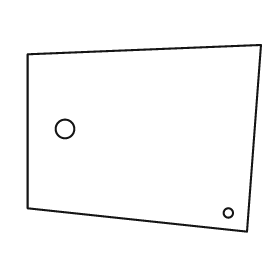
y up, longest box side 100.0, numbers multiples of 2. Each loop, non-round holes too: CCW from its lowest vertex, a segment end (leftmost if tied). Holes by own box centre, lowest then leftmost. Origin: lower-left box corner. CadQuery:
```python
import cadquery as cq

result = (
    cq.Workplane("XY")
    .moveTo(94.0, 0.0)
    .lineTo(100.0, 80.0)
    .lineTo(0.0, 76.0)
    .lineTo(0.0, 10.0)
    .close()
    .moveTo(86.0, 8.0)
    .circle(2.0)
    .moveTo(16.0, 44.0)
    .circle(4.0)
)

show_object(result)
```